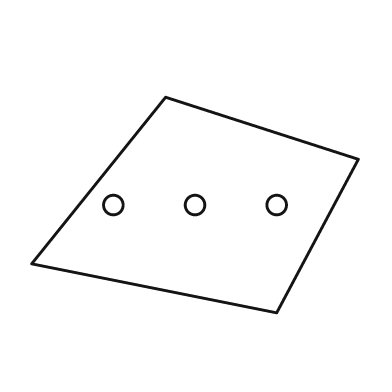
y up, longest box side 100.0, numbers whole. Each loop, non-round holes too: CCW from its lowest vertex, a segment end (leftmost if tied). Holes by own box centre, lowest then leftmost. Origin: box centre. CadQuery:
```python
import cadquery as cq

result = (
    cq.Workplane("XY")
    .moveTo(25.0, -33.0)
    .lineTo(50.0, 14.0)
    .lineTo(-9.0, 33.0)
    .lineTo(-50.0, -18.0)
    .close()
    .moveTo(-25.0, 0.0)
    .circle(3.0)
    .moveTo(0.0, 0.0)
    .circle(3.0)
    .moveTo(25.0, 0.0)
    .circle(3.0)
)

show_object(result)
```